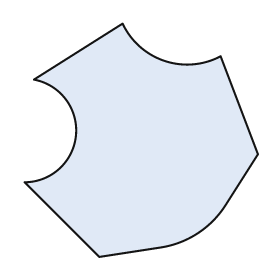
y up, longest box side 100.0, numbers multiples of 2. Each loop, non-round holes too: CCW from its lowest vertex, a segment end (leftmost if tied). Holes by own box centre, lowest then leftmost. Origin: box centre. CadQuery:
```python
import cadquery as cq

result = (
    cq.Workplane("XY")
    .moveTo(-18.0, -50.0)
    .lineTo(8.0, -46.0)
    .threePointArc((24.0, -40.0), (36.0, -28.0))
    .lineTo(50.0, -6.0)
    .lineTo(34.0, 36.0)
    .threePointArc((10.0, 34.0), (-8.0, 50.0))
    .lineTo(-46.0, 26.0)
    .threePointArc((-28.0, 2.0), (-50.0, -18.0))
    .close()
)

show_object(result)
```